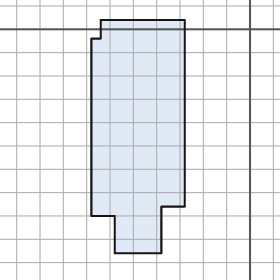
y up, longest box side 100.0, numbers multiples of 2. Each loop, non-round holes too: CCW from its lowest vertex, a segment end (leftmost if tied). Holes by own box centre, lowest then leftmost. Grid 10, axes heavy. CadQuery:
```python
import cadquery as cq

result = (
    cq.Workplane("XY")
    .moveTo(-58.0, -96.0)
    .lineTo(-38.0, -96.0)
    .lineTo(-38.0, -76.0)
    .lineTo(-28.0, -76.0)
    .lineTo(-28.0, 4.0)
    .lineTo(-64.0, 4.0)
    .lineTo(-64.0, -4.0)
    .lineTo(-68.0, -4.0)
    .lineTo(-68.0, -80.0)
    .lineTo(-58.0, -80.0)
    .close()
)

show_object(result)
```